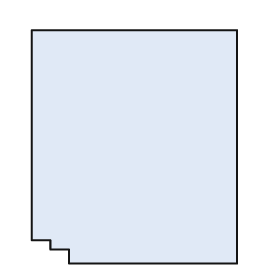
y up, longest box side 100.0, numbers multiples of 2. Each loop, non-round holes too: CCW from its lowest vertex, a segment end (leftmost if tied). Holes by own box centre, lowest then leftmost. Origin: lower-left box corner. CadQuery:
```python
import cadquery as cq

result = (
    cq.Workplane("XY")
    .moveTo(16.0, 0.0)
    .lineTo(88.0, 0.0)
    .lineTo(88.0, 100.0)
    .lineTo(0.0, 100.0)
    .lineTo(0.0, 10.0)
    .lineTo(8.0, 10.0)
    .lineTo(8.0, 6.0)
    .lineTo(16.0, 6.0)
    .close()
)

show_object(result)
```